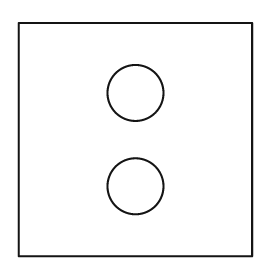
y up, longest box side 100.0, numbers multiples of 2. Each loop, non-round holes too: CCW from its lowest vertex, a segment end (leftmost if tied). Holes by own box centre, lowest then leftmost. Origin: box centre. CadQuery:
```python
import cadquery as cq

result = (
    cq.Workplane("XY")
    .moveTo(-50.0, -50.0)
    .lineTo(50.0, -50.0)
    .lineTo(50.0, 50.0)
    .lineTo(-50.0, 50.0)
    .close()
    .moveTo(0.0, -20.0)
    .circle(12.0)
    .moveTo(0.0, 20.0)
    .circle(12.0)
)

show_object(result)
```